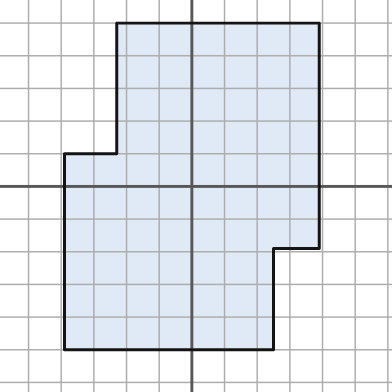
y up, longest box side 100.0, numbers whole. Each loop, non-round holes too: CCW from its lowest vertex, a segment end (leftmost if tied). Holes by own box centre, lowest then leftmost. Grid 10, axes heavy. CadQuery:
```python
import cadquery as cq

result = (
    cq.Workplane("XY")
    .moveTo(-39.0, -50.0)
    .lineTo(25.0, -50.0)
    .lineTo(25.0, -19.0)
    .lineTo(39.0, -19.0)
    .lineTo(39.0, 50.0)
    .lineTo(-23.0, 50.0)
    .lineTo(-23.0, 10.0)
    .lineTo(-39.0, 10.0)
    .close()
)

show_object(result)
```